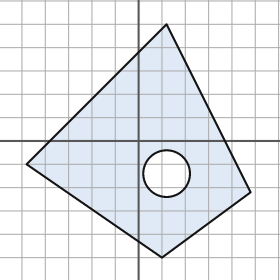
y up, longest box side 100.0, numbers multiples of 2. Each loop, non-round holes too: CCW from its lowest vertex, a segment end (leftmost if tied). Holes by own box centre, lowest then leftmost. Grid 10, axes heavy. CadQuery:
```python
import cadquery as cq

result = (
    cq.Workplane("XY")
    .moveTo(10.0, -50.0)
    .lineTo(48.0, -22.0)
    .lineTo(12.0, 50.0)
    .lineTo(-48.0, -10.0)
    .close()
    .moveTo(12.0, -14.0)
    .circle(10.0)
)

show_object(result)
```